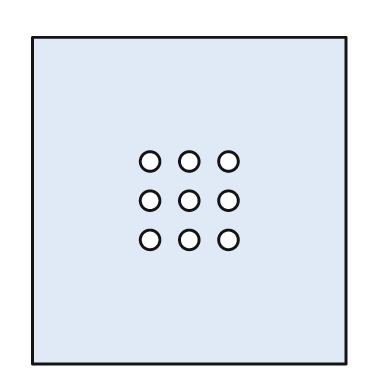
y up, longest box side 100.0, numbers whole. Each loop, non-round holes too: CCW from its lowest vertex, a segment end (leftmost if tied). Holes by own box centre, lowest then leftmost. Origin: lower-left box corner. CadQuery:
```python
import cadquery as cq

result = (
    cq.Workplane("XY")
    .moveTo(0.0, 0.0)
    .lineTo(96.0, 0.0)
    .lineTo(96.0, 100.0)
    .lineTo(0.0, 100.0)
    .close()
    .moveTo(36.0, 38.0)
    .circle(3.0)
    .moveTo(48.0, 38.0)
    .circle(3.0)
    .moveTo(60.0, 38.0)
    .circle(3.0)
    .moveTo(36.0, 50.0)
    .circle(3.0)
    .moveTo(48.0, 50.0)
    .circle(3.0)
    .moveTo(60.0, 50.0)
    .circle(3.0)
    .moveTo(36.0, 62.0)
    .circle(3.0)
    .moveTo(48.0, 62.0)
    .circle(3.0)
    .moveTo(60.0, 62.0)
    .circle(3.0)
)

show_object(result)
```